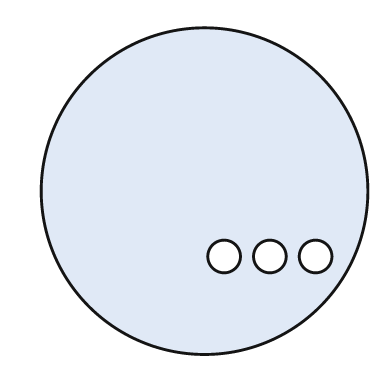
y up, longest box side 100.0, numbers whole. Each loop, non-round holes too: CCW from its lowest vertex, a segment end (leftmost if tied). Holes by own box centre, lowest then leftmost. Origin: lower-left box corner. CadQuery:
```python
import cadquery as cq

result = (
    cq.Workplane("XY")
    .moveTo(50.0, 50.0)
    .circle(50.0)
    .moveTo(56.0, 30.0)
    .circle(5.0)
    .moveTo(70.0, 30.0)
    .circle(5.0)
    .moveTo(84.0, 30.0)
    .circle(5.0)
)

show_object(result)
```